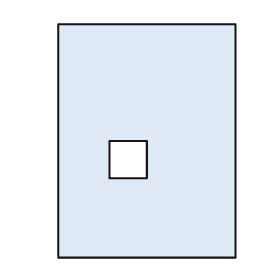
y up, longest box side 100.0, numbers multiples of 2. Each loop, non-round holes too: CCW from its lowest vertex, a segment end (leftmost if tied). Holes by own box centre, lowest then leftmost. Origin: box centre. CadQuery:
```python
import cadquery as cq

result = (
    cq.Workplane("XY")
    .moveTo(-38.0, -50.0)
    .lineTo(38.0, -50.0)
    .lineTo(38.0, 50.0)
    .lineTo(-38.0, 50.0)
    .close()
    .moveTo(-16.0, -16.0)
    .lineTo(0.0, -16.0)
    .lineTo(0.0, 0.0)
    .lineTo(-16.0, 0.0)
    .close()
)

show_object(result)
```